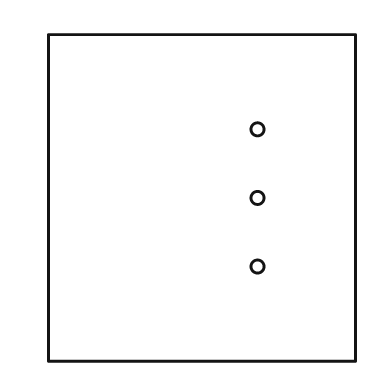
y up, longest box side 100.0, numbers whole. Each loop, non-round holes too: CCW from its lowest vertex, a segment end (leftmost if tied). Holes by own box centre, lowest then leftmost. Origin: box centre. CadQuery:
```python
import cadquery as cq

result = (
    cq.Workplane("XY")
    .moveTo(-47.0, -50.0)
    .lineTo(47.0, -50.0)
    .lineTo(47.0, 50.0)
    .lineTo(-47.0, 50.0)
    .close()
    .moveTo(17.0, -21.0)
    .circle(2.0)
    .moveTo(17.0, 0.0)
    .circle(2.0)
    .moveTo(17.0, 21.0)
    .circle(2.0)
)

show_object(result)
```